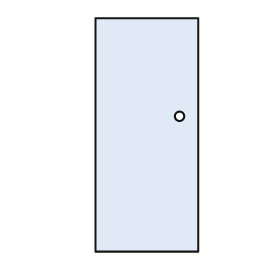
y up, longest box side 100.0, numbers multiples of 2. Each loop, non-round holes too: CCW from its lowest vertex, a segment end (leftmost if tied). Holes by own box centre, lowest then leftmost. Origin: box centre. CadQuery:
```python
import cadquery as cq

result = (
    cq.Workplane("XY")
    .moveTo(-22.0, -50.0)
    .lineTo(22.0, -50.0)
    .lineTo(22.0, 50.0)
    .lineTo(-22.0, 50.0)
    .close()
    .moveTo(14.0, 8.0)
    .circle(2.0)
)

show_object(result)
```